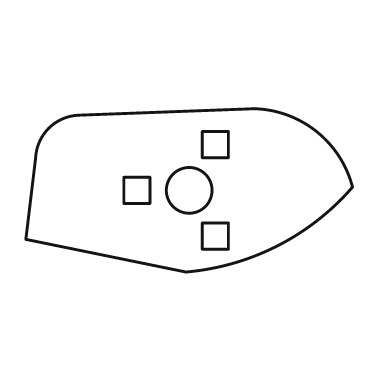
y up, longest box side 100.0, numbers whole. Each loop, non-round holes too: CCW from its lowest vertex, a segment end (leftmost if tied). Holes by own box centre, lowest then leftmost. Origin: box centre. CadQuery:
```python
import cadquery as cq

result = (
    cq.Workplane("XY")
    .moveTo(-1.0, -25.0)
    .threePointArc((27.0, -17.0), (50.0, 1.0))
    .threePointArc((39.0, 18.0), (20.0, 25.0))
    .lineTo(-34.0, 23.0)
    .threePointArc((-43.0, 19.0), (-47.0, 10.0))
    .lineTo(-50.0, -15.0)
    .close()
    .moveTo(4.0, -18.0)
    .lineTo(12.0, -18.0)
    .lineTo(12.0, -10.0)
    .lineTo(4.0, -10.0)
    .close()
    .moveTo(-20.0, -4.0)
    .lineTo(-12.0, -4.0)
    .lineTo(-12.0, 4.0)
    .lineTo(-20.0, 4.0)
    .close()
    .moveTo(0.0, 0.0)
    .circle(7.0)
    .moveTo(4.0, 10.0)
    .lineTo(12.0, 10.0)
    .lineTo(12.0, 18.0)
    .lineTo(4.0, 18.0)
    .close()
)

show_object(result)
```